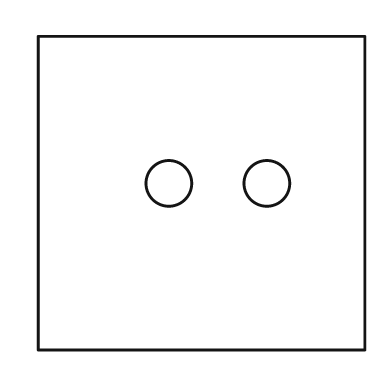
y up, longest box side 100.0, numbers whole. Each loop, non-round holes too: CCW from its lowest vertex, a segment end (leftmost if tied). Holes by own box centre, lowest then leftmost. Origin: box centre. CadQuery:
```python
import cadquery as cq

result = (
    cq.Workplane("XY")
    .moveTo(-50.0, -48.0)
    .lineTo(50.0, -48.0)
    .lineTo(50.0, 48.0)
    .lineTo(-50.0, 48.0)
    .close()
    .moveTo(-10.0, 3.0)
    .circle(7.0)
    .moveTo(20.0, 3.0)
    .circle(7.0)
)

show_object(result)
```